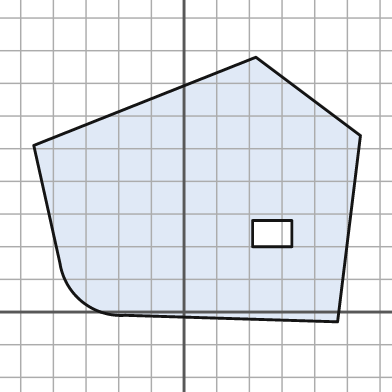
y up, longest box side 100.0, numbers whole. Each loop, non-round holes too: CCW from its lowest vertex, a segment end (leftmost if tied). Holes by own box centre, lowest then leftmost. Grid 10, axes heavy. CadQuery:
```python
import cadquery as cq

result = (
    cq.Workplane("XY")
    .moveTo(47.0, -3.0)
    .lineTo(54.0, 54.0)
    .lineTo(22.0, 78.0)
    .lineTo(-46.0, 51.0)
    .lineTo(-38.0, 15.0)
    .threePointArc((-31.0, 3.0), (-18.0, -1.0))
    .close()
    .moveTo(21.0, 20.0)
    .lineTo(33.0, 20.0)
    .lineTo(33.0, 28.0)
    .lineTo(21.0, 28.0)
    .close()
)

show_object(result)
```